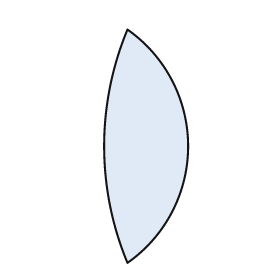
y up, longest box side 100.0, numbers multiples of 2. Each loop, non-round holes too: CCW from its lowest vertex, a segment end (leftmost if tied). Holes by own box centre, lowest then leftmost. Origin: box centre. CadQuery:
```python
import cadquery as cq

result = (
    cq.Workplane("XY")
    .moveTo(-8.0, -50.0)
    .threePointArc((18.0, 0.0), (-8.0, 50.0))
    .threePointArc((-18.0, 0.0), (-8.0, -50.0))
    .close()
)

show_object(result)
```